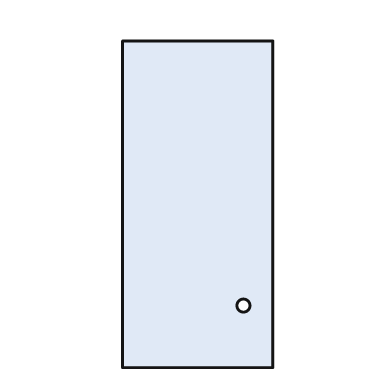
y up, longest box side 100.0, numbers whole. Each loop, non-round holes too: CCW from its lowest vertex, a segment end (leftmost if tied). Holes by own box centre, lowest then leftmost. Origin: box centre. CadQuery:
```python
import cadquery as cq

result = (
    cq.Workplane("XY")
    .moveTo(-23.0, -50.0)
    .lineTo(23.0, -50.0)
    .lineTo(23.0, 50.0)
    .lineTo(-23.0, 50.0)
    .close()
    .moveTo(14.0, -31.0)
    .circle(2.0)
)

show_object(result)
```